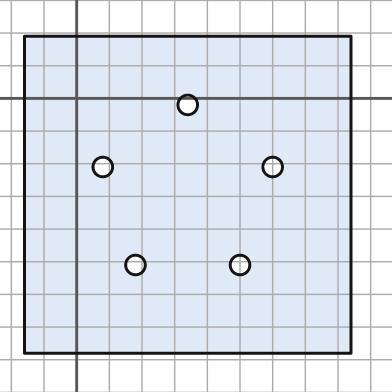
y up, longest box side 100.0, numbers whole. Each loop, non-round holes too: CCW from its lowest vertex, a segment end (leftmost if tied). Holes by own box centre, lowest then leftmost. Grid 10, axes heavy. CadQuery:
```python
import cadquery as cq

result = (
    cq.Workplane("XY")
    .moveTo(-16.0, -78.0)
    .lineTo(84.0, -78.0)
    .lineTo(84.0, 19.0)
    .lineTo(-16.0, 19.0)
    .close()
    .moveTo(18.0, -51.0)
    .circle(3.0)
    .moveTo(50.0, -51.0)
    .circle(3.0)
    .moveTo(8.0, -21.0)
    .circle(3.0)
    .moveTo(60.0, -21.0)
    .circle(3.0)
    .moveTo(34.0, -2.0)
    .circle(3.0)
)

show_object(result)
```